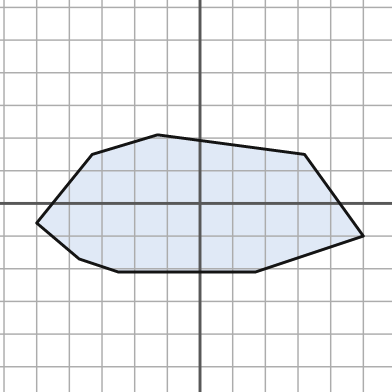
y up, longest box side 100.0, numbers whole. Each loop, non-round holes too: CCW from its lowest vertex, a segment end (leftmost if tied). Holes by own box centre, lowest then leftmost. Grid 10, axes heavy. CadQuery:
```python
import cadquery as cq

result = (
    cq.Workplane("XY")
    .moveTo(-25.0, -21.0)
    .lineTo(17.0, -21.0)
    .lineTo(50.0, -10.0)
    .lineTo(32.0, 15.0)
    .lineTo(-13.0, 21.0)
    .lineTo(-33.0, 15.0)
    .lineTo(-50.0, -6.0)
    .lineTo(-37.0, -17.0)
    .close()
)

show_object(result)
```